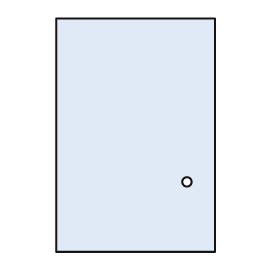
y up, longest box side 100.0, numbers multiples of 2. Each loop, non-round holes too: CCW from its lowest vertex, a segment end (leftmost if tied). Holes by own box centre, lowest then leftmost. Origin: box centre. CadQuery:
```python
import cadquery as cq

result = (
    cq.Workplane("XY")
    .moveTo(-34.0, -50.0)
    .lineTo(34.0, -50.0)
    .lineTo(34.0, 50.0)
    .lineTo(-34.0, 50.0)
    .close()
    .moveTo(22.0, -20.0)
    .circle(2.0)
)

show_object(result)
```